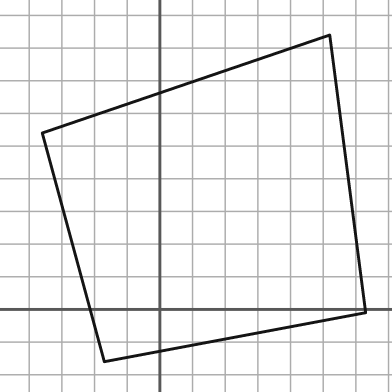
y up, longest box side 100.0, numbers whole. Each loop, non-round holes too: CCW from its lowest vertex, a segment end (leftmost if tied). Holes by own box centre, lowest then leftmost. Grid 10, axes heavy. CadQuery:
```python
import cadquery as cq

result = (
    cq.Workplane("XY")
    .moveTo(-17.0, -16.0)
    .lineTo(63.0, -1.0)
    .lineTo(52.0, 84.0)
    .lineTo(-36.0, 54.0)
    .close()
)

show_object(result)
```